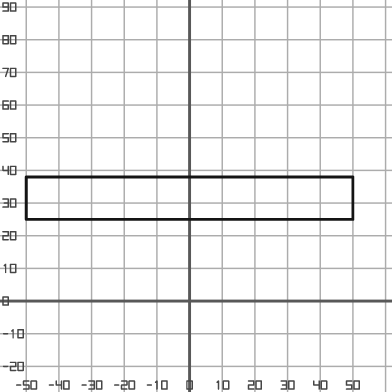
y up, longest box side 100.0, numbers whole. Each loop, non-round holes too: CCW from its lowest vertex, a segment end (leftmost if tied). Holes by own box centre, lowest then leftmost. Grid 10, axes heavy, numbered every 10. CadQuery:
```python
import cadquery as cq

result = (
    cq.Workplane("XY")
    .moveTo(-50.0, 25.0)
    .lineTo(50.0, 25.0)
    .lineTo(50.0, 38.0)
    .lineTo(-50.0, 38.0)
    .close()
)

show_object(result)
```